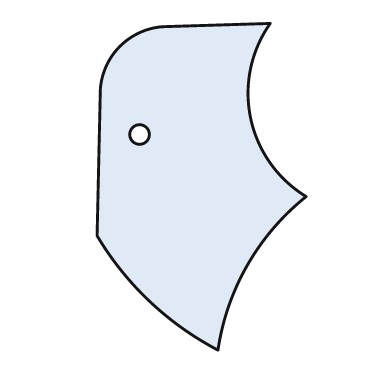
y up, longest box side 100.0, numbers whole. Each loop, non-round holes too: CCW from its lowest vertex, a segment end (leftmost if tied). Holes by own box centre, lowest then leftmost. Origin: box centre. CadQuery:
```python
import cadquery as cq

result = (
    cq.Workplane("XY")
    .moveTo(5.0, -50.0)
    .threePointArc((14.0, -24.0), (32.0, -3.0))
    .threePointArc((15.0, 21.0), (21.0, 50.0))
    .lineTo(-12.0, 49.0)
    .threePointArc((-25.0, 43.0), (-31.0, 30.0))
    .lineTo(-32.0, -15.0)
    .threePointArc((-16.0, -35.0), (5.0, -50.0))
    .close()
    .moveTo(-19.0, 16.0)
    .circle(3.0)
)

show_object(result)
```